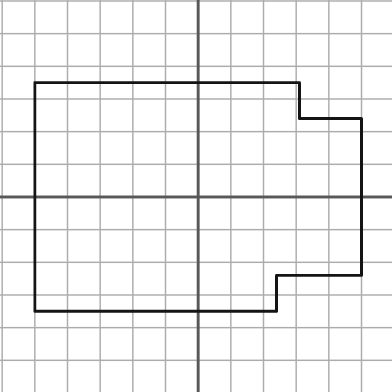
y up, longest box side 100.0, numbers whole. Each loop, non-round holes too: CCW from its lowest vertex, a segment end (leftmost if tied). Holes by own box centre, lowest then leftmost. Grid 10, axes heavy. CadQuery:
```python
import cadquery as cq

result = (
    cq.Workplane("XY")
    .moveTo(-50.0, -35.0)
    .lineTo(24.0, -35.0)
    .lineTo(24.0, -24.0)
    .lineTo(50.0, -24.0)
    .lineTo(50.0, 24.0)
    .lineTo(31.0, 24.0)
    .lineTo(31.0, 35.0)
    .lineTo(-50.0, 35.0)
    .close()
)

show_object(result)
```